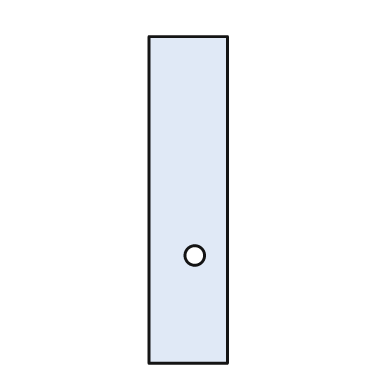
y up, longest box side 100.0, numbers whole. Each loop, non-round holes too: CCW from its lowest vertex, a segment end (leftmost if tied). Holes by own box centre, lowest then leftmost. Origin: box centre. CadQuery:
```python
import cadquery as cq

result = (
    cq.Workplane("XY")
    .moveTo(-12.0, -50.0)
    .lineTo(12.0, -50.0)
    .lineTo(12.0, 50.0)
    .lineTo(-12.0, 50.0)
    .close()
    .moveTo(2.0, -17.0)
    .circle(3.0)
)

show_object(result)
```